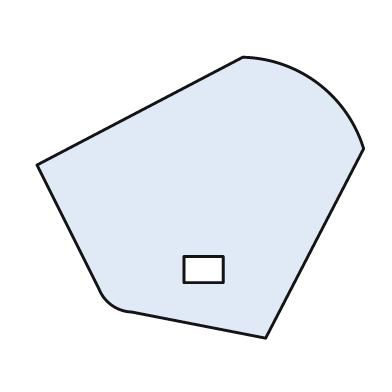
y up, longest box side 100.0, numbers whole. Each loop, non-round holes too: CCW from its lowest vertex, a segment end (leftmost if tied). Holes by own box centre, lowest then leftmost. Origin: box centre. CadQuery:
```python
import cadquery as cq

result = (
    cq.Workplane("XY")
    .moveTo(20.0, -43.0)
    .lineTo(50.0, 15.0)
    .threePointArc((36.0, 35.0), (13.0, 43.0))
    .lineTo(-50.0, 10.0)
    .lineTo(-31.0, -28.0)
    .threePointArc((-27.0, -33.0), (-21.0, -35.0))
    .close()
    .moveTo(-5.0, -26.0)
    .lineTo(7.0, -26.0)
    .lineTo(7.0, -18.0)
    .lineTo(-5.0, -18.0)
    .close()
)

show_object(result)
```